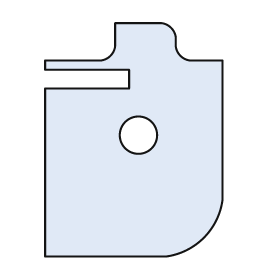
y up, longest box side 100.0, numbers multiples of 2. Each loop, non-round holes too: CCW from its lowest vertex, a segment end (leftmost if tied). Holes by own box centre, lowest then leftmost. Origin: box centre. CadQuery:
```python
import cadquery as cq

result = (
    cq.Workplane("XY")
    .moveTo(-38.0, -50.0)
    .lineTo(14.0, -50.0)
    .threePointArc((30.0, -42.0), (38.0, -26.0))
    .lineTo(38.0, 34.0)
    .lineTo(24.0, 34.0)
    .threePointArc((20.0, 36.0), (18.0, 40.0))
    .lineTo(18.0, 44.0)
    .threePointArc((16.0, 48.0), (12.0, 50.0))
    .lineTo(-8.0, 50.0)
    .lineTo(-8.0, 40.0)
    .threePointArc((-10.0, 36.0), (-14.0, 34.0))
    .lineTo(-38.0, 34.0)
    .lineTo(-38.0, 30.0)
    .lineTo(-2.0, 30.0)
    .lineTo(-2.0, 22.0)
    .lineTo(-38.0, 22.0)
    .close()
    .moveTo(2.0, 2.0)
    .circle(8.0)
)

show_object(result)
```